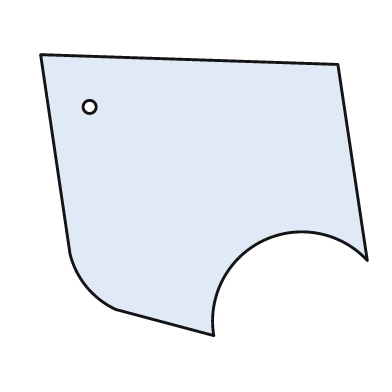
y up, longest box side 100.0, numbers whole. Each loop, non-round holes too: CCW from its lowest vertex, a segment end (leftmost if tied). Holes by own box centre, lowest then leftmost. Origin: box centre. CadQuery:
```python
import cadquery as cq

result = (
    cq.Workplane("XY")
    .moveTo(3.0, -43.0)
    .threePointArc((18.0, -14.0), (50.0, -20.0))
    .lineTo(41.0, 40.0)
    .lineTo(-50.0, 43.0)
    .lineTo(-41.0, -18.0)
    .threePointArc((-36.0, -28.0), (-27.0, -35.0))
    .close()
    .moveTo(-35.0, 27.0)
    .circle(2.0)
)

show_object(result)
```